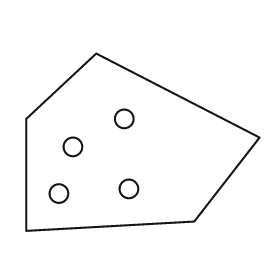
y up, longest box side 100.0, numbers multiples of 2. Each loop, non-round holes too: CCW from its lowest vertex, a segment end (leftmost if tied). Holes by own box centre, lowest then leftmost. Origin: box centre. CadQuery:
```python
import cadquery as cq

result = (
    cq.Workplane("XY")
    .moveTo(-50.0, -38.0)
    .lineTo(22.0, -34.0)
    .lineTo(50.0, 2.0)
    .lineTo(-20.0, 38.0)
    .lineTo(-50.0, 10.0)
    .close()
    .moveTo(-36.0, -22.0)
    .circle(4.0)
    .moveTo(-6.0, -20.0)
    .circle(4.0)
    .moveTo(-30.0, -2.0)
    .circle(4.0)
    .moveTo(-8.0, 10.0)
    .circle(4.0)
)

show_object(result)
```